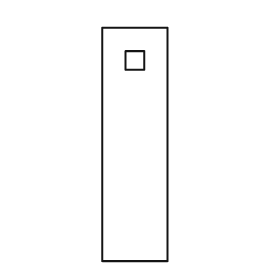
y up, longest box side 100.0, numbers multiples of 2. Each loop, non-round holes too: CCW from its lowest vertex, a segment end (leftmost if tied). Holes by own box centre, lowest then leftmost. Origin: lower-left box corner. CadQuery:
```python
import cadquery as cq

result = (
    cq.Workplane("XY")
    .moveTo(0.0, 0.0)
    .lineTo(28.0, 0.0)
    .lineTo(28.0, 100.0)
    .lineTo(0.0, 100.0)
    .close()
    .moveTo(10.0, 82.0)
    .lineTo(18.0, 82.0)
    .lineTo(18.0, 90.0)
    .lineTo(10.0, 90.0)
    .close()
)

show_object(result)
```